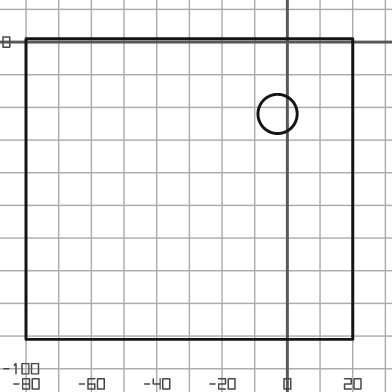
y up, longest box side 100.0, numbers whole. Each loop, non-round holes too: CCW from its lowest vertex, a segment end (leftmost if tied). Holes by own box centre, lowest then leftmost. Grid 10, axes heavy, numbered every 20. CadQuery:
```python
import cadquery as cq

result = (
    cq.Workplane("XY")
    .moveTo(-80.0, -91.0)
    .lineTo(20.0, -91.0)
    .lineTo(20.0, 1.0)
    .lineTo(-80.0, 1.0)
    .close()
    .moveTo(-3.0, -22.0)
    .circle(6.0)
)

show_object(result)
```